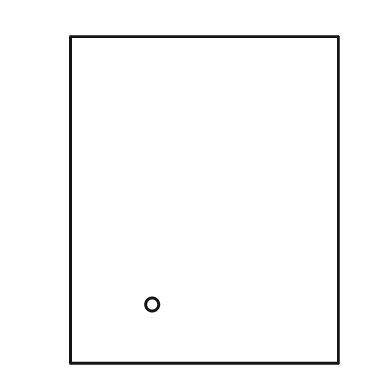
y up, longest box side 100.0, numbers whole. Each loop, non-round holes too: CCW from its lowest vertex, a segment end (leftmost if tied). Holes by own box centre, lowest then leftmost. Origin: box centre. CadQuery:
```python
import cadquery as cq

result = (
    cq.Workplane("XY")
    .moveTo(-41.0, -50.0)
    .lineTo(41.0, -50.0)
    .lineTo(41.0, 50.0)
    .lineTo(-41.0, 50.0)
    .close()
    .moveTo(-16.0, -32.0)
    .circle(2.0)
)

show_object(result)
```